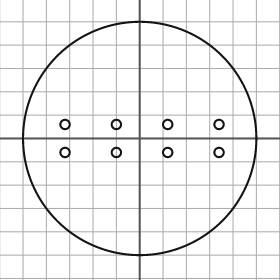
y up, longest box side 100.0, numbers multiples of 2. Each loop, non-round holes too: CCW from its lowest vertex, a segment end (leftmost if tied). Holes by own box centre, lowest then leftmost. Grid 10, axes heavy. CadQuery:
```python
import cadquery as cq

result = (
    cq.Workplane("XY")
    .moveTo(0.0, 0.0)
    .circle(50.0)
    .moveTo(-32.0, -6.0)
    .circle(2.0)
    .moveTo(-10.0, -6.0)
    .circle(2.0)
    .moveTo(12.0, -6.0)
    .circle(2.0)
    .moveTo(34.0, -6.0)
    .circle(2.0)
    .moveTo(-32.0, 6.0)
    .circle(2.0)
    .moveTo(-10.0, 6.0)
    .circle(2.0)
    .moveTo(12.0, 6.0)
    .circle(2.0)
    .moveTo(34.0, 6.0)
    .circle(2.0)
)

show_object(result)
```